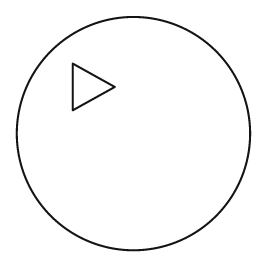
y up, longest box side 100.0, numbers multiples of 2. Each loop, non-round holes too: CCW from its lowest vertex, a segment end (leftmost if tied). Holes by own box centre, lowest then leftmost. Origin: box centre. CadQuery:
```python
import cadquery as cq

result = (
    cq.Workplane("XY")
    .moveTo(0.0, 0.0)
    .circle(50.0)
    .moveTo(-26.0, 10.0)
    .lineTo(-8.0, 20.0)
    .lineTo(-26.0, 30.0)
    .close()
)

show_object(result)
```